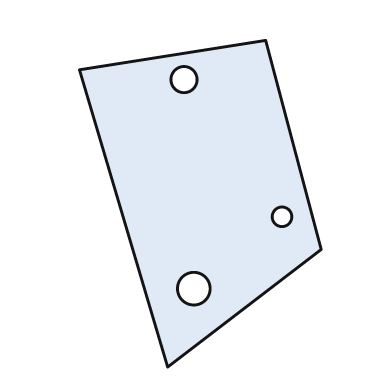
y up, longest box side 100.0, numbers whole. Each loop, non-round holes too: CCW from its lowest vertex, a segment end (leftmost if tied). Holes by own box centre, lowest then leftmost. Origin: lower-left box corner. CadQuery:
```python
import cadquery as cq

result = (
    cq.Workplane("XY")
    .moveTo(27.0, 0.0)
    .lineTo(74.0, 36.0)
    .lineTo(57.0, 100.0)
    .lineTo(0.0, 91.0)
    .close()
    .moveTo(35.0, 24.0)
    .circle(5.0)
    .moveTo(62.0, 46.0)
    .circle(3.0)
    .moveTo(32.0, 88.0)
    .circle(4.0)
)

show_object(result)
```